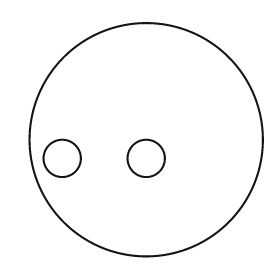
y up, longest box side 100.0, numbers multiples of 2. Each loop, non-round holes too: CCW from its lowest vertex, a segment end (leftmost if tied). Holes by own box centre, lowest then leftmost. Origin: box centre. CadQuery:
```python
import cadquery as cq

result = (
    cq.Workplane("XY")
    .moveTo(0.0, 0.0)
    .circle(50.0)
    .moveTo(-36.0, -8.0)
    .circle(8.0)
    .moveTo(0.0, -8.0)
    .circle(8.0)
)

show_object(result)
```